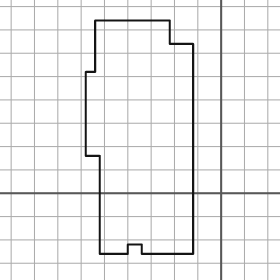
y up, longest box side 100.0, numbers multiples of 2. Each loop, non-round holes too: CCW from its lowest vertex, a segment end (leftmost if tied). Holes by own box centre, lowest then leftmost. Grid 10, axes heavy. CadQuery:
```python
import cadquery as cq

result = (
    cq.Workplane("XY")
    .moveTo(-52.0, -26.0)
    .lineTo(-40.0, -26.0)
    .lineTo(-40.0, -22.0)
    .lineTo(-34.0, -22.0)
    .lineTo(-34.0, -26.0)
    .lineTo(-12.0, -26.0)
    .lineTo(-12.0, 64.0)
    .lineTo(-22.0, 64.0)
    .lineTo(-22.0, 74.0)
    .lineTo(-54.0, 74.0)
    .lineTo(-54.0, 52.0)
    .lineTo(-58.0, 52.0)
    .lineTo(-58.0, 16.0)
    .lineTo(-52.0, 16.0)
    .close()
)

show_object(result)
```